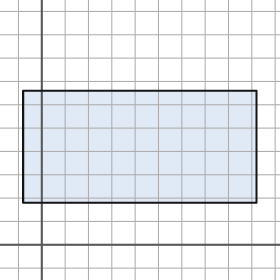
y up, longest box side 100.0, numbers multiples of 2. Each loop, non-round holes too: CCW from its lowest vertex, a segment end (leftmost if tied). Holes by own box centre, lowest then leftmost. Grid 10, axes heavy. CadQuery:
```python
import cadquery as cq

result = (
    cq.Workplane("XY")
    .moveTo(-8.0, 18.0)
    .lineTo(92.0, 18.0)
    .lineTo(92.0, 66.0)
    .lineTo(-8.0, 66.0)
    .close()
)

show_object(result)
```